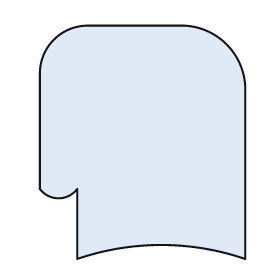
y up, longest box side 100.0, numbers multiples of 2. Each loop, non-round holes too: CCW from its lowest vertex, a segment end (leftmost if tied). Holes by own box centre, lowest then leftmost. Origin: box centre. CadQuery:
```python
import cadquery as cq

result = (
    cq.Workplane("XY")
    .moveTo(-28.0, -50.0)
    .threePointArc((8.0, -44.0), (44.0, -50.0))
    .lineTo(44.0, 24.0)
    .threePointArc((36.0, 42.0), (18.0, 50.0))
    .lineTo(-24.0, 50.0)
    .threePointArc((-38.0, 44.0), (-44.0, 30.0))
    .lineTo(-44.0, -20.0)
    .threePointArc((-36.0, -24.0), (-28.0, -20.0))
    .close()
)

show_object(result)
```